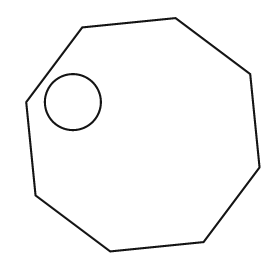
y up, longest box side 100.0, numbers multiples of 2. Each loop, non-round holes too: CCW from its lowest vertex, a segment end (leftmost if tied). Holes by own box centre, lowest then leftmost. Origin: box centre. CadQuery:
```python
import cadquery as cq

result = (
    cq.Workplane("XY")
    .moveTo(-14.0, -50.0)
    .lineTo(26.0, -46.0)
    .lineTo(50.0, -14.0)
    .lineTo(46.0, 26.0)
    .lineTo(14.0, 50.0)
    .lineTo(-26.0, 46.0)
    .lineTo(-50.0, 14.0)
    .lineTo(-46.0, -26.0)
    .close()
    .moveTo(-30.0, 14.0)
    .circle(12.0)
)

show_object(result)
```